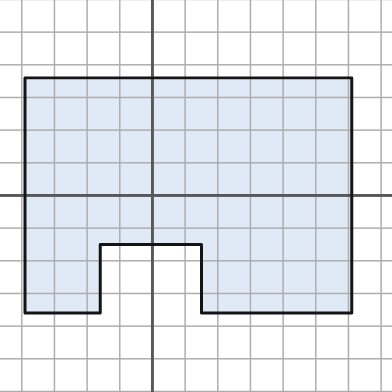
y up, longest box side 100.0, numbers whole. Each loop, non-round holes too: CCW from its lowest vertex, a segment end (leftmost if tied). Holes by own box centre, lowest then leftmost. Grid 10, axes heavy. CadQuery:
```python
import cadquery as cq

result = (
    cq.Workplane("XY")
    .moveTo(-39.0, -36.0)
    .lineTo(-16.0, -36.0)
    .lineTo(-16.0, -15.0)
    .lineTo(15.0, -15.0)
    .lineTo(15.0, -36.0)
    .lineTo(61.0, -36.0)
    .lineTo(61.0, 36.0)
    .lineTo(-39.0, 36.0)
    .close()
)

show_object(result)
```